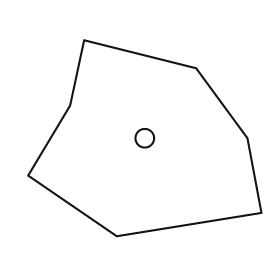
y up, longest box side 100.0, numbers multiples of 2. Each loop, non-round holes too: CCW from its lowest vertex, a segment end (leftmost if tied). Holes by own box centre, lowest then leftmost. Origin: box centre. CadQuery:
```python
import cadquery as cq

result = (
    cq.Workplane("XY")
    .moveTo(-12.0, -42.0)
    .lineTo(50.0, -32.0)
    .lineTo(44.0, 0.0)
    .lineTo(22.0, 30.0)
    .lineTo(-26.0, 42.0)
    .lineTo(-32.0, 14.0)
    .lineTo(-50.0, -16.0)
    .close()
    .moveTo(0.0, 0.0)
    .circle(4.0)
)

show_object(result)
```